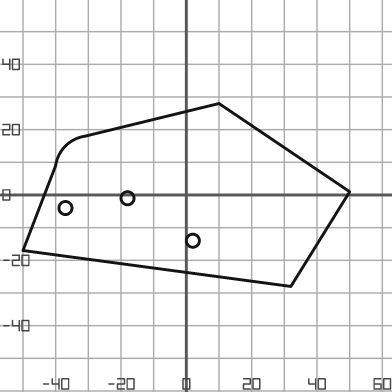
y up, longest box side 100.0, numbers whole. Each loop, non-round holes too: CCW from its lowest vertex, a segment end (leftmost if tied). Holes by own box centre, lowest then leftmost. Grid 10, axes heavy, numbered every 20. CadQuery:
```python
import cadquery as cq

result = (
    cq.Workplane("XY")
    .moveTo(32.0, -28.0)
    .lineTo(50.0, 1.0)
    .lineTo(10.0, 28.0)
    .lineTo(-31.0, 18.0)
    .threePointArc((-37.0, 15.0), (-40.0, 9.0))
    .lineTo(-50.0, -17.0)
    .close()
    .moveTo(2.0, -14.0)
    .circle(2.0)
    .moveTo(-37.0, -4.0)
    .circle(2.0)
    .moveTo(-18.0, -1.0)
    .circle(2.0)
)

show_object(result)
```